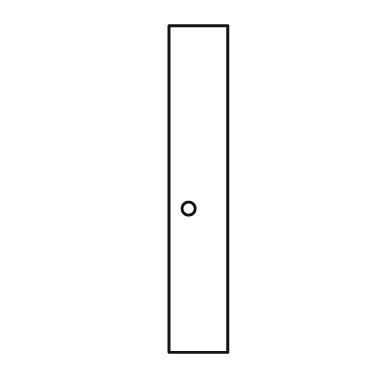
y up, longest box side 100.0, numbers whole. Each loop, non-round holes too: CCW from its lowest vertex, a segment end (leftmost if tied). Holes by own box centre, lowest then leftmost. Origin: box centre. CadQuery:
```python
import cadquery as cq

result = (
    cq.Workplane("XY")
    .moveTo(-9.0, -50.0)
    .lineTo(9.0, -50.0)
    .lineTo(9.0, 50.0)
    .lineTo(-9.0, 50.0)
    .close()
    .moveTo(-3.0, -6.0)
    .circle(2.0)
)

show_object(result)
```